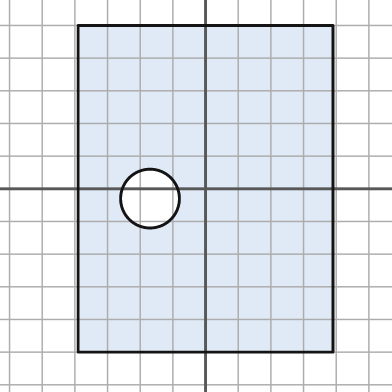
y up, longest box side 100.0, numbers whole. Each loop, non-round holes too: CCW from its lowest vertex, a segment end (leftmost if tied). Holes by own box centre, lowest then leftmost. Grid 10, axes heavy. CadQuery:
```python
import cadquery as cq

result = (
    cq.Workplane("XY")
    .moveTo(-39.0, -50.0)
    .lineTo(39.0, -50.0)
    .lineTo(39.0, 50.0)
    .lineTo(-39.0, 50.0)
    .close()
    .moveTo(-17.0, -3.0)
    .circle(9.0)
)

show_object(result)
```